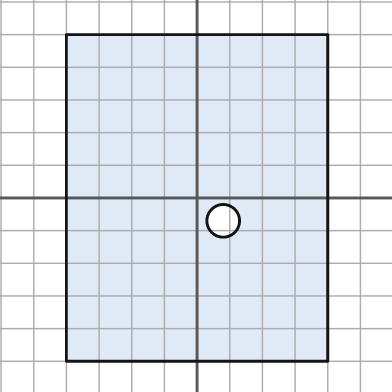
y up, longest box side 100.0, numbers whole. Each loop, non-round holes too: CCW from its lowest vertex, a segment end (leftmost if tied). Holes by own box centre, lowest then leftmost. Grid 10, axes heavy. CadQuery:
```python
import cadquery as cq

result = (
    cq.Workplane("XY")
    .moveTo(-40.0, -50.0)
    .lineTo(40.0, -50.0)
    .lineTo(40.0, 50.0)
    .lineTo(-40.0, 50.0)
    .close()
    .moveTo(8.0, -7.0)
    .circle(5.0)
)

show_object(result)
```